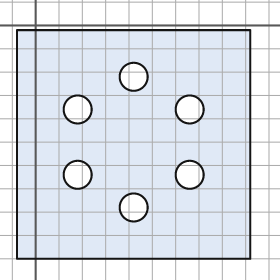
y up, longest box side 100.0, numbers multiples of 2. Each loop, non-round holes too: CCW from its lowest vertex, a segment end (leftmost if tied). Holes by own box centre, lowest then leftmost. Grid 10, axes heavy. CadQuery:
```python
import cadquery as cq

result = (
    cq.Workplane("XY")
    .moveTo(-8.0, -100.0)
    .lineTo(92.0, -100.0)
    .lineTo(92.0, -2.0)
    .lineTo(-8.0, -2.0)
    .close()
    .moveTo(42.0, -78.0)
    .circle(6.0)
    .moveTo(18.0, -64.0)
    .circle(6.0)
    .moveTo(66.0, -64.0)
    .circle(6.0)
    .moveTo(18.0, -36.0)
    .circle(6.0)
    .moveTo(66.0, -36.0)
    .circle(6.0)
    .moveTo(42.0, -22.0)
    .circle(6.0)
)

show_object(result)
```